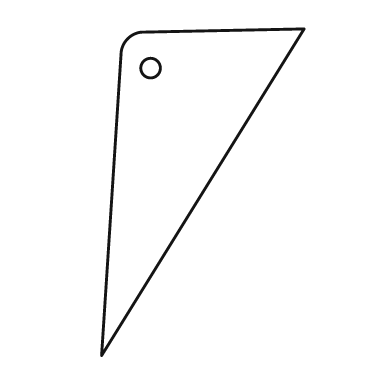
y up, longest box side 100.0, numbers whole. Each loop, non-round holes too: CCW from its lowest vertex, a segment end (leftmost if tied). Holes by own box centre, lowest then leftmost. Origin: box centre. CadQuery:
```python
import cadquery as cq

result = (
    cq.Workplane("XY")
    .moveTo(-31.0, -50.0)
    .lineTo(31.0, 50.0)
    .lineTo(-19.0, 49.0)
    .threePointArc((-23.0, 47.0), (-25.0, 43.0))
    .close()
    .moveTo(-16.0, 38.0)
    .circle(3.0)
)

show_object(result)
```